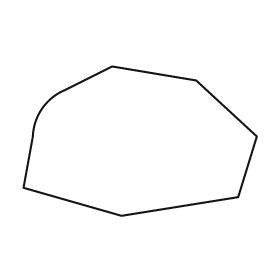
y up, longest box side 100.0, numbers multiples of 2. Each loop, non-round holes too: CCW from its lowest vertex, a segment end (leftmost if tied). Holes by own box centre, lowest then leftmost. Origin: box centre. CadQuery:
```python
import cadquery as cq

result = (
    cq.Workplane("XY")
    .moveTo(-8.0, -32.0)
    .lineTo(42.0, -24.0)
    .lineTo(50.0, 2.0)
    .lineTo(24.0, 26.0)
    .lineTo(-12.0, 32.0)
    .lineTo(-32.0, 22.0)
    .threePointArc((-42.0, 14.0), (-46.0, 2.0))
    .lineTo(-50.0, -20.0)
    .close()
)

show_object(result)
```